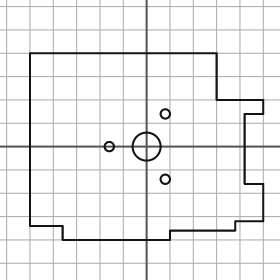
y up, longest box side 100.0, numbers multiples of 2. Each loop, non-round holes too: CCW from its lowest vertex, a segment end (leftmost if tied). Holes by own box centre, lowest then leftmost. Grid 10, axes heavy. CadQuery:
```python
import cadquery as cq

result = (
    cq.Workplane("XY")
    .moveTo(-36.0, -40.0)
    .lineTo(10.0, -40.0)
    .lineTo(10.0, -36.0)
    .lineTo(38.0, -36.0)
    .lineTo(38.0, -32.0)
    .lineTo(50.0, -32.0)
    .lineTo(50.0, -16.0)
    .lineTo(42.0, -16.0)
    .lineTo(42.0, 14.0)
    .lineTo(50.0, 14.0)
    .lineTo(50.0, 20.0)
    .lineTo(30.0, 20.0)
    .lineTo(30.0, 40.0)
    .lineTo(-50.0, 40.0)
    .lineTo(-50.0, -34.0)
    .lineTo(-36.0, -34.0)
    .close()
    .moveTo(8.0, -14.0)
    .circle(2.0)
    .moveTo(-16.0, 0.0)
    .circle(2.0)
    .moveTo(0.0, 0.0)
    .circle(6.0)
    .moveTo(8.0, 14.0)
    .circle(2.0)
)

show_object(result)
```